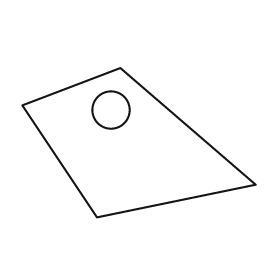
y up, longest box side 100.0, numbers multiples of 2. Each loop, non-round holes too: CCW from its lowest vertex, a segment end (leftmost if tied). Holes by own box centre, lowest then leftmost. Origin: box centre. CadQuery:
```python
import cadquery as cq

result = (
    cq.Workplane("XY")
    .moveTo(-18.0, -32.0)
    .lineTo(50.0, -18.0)
    .lineTo(-8.0, 32.0)
    .lineTo(-50.0, 16.0)
    .close()
    .moveTo(-12.0, 14.0)
    .circle(8.0)
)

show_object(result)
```